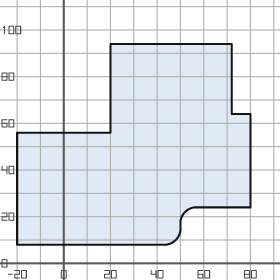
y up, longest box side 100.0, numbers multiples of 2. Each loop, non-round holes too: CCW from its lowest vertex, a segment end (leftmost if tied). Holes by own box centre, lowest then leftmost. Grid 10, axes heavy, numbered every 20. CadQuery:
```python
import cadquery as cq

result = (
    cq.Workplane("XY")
    .moveTo(-20.0, 8.0)
    .lineTo(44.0, 8.0)
    .threePointArc((48.0, 10.0), (50.0, 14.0))
    .lineTo(50.0, 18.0)
    .threePointArc((52.0, 22.0), (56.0, 24.0))
    .lineTo(80.0, 24.0)
    .lineTo(80.0, 64.0)
    .lineTo(72.0, 64.0)
    .lineTo(72.0, 94.0)
    .lineTo(20.0, 94.0)
    .lineTo(20.0, 56.0)
    .lineTo(-20.0, 56.0)
    .close()
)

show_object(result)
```